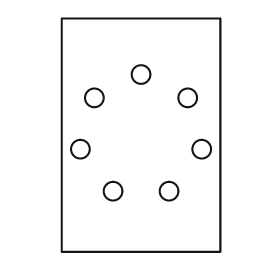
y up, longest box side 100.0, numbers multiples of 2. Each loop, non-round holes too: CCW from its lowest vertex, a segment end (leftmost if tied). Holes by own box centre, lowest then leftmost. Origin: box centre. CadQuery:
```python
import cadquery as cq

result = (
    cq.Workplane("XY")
    .moveTo(-34.0, -50.0)
    .lineTo(34.0, -50.0)
    .lineTo(34.0, 50.0)
    .lineTo(-34.0, 50.0)
    .close()
    .moveTo(-12.0, -24.0)
    .circle(4.0)
    .moveTo(12.0, -24.0)
    .circle(4.0)
    .moveTo(-26.0, -6.0)
    .circle(4.0)
    .moveTo(26.0, -6.0)
    .circle(4.0)
    .moveTo(-20.0, 16.0)
    .circle(4.0)
    .moveTo(20.0, 16.0)
    .circle(4.0)
    .moveTo(0.0, 26.0)
    .circle(4.0)
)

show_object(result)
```